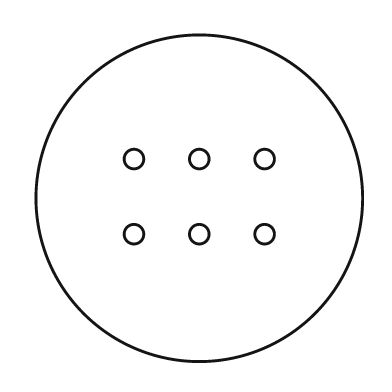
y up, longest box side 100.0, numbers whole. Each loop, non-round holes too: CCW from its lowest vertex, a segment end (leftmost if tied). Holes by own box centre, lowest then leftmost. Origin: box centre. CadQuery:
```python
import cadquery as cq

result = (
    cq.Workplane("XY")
    .moveTo(0.0, 0.0)
    .circle(50.0)
    .moveTo(-20.0, -11.0)
    .circle(3.0)
    .moveTo(0.0, -11.0)
    .circle(3.0)
    .moveTo(20.0, -11.0)
    .circle(3.0)
    .moveTo(-20.0, 12.0)
    .circle(3.0)
    .moveTo(0.0, 12.0)
    .circle(3.0)
    .moveTo(20.0, 12.0)
    .circle(3.0)
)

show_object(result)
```